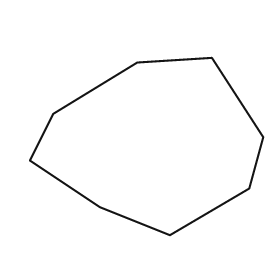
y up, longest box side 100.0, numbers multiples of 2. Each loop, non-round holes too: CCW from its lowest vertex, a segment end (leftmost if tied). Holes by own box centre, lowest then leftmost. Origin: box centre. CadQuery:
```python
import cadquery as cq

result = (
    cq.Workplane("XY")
    .moveTo(10.0, -38.0)
    .lineTo(44.0, -18.0)
    .lineTo(50.0, 4.0)
    .lineTo(28.0, 38.0)
    .lineTo(-4.0, 36.0)
    .lineTo(-40.0, 14.0)
    .lineTo(-50.0, -6.0)
    .lineTo(-20.0, -26.0)
    .close()
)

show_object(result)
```